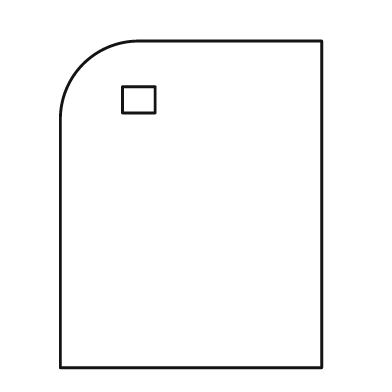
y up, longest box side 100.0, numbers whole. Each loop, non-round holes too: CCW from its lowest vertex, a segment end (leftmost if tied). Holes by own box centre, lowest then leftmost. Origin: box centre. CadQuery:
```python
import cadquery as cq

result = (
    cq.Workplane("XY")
    .moveTo(-40.0, -50.0)
    .lineTo(40.0, -50.0)
    .lineTo(40.0, 50.0)
    .lineTo(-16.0, 50.0)
    .threePointArc((-33.0, 43.0), (-40.0, 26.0))
    .close()
    .moveTo(-21.0, 28.0)
    .lineTo(-11.0, 28.0)
    .lineTo(-11.0, 36.0)
    .lineTo(-21.0, 36.0)
    .close()
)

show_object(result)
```